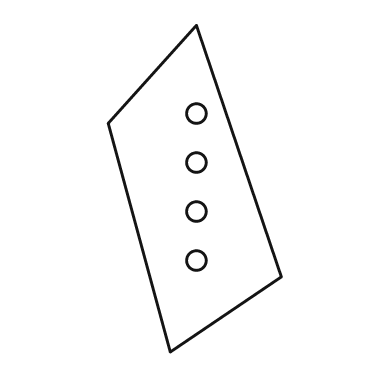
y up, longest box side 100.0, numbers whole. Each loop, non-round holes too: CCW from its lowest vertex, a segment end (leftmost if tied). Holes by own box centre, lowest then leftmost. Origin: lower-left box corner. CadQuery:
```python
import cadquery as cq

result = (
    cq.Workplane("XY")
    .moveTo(19.0, 0.0)
    .lineTo(53.0, 23.0)
    .lineTo(27.0, 100.0)
    .lineTo(0.0, 70.0)
    .close()
    .moveTo(27.0, 28.0)
    .circle(3.0)
    .moveTo(27.0, 43.0)
    .circle(3.0)
    .moveTo(27.0, 58.0)
    .circle(3.0)
    .moveTo(27.0, 73.0)
    .circle(3.0)
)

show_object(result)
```